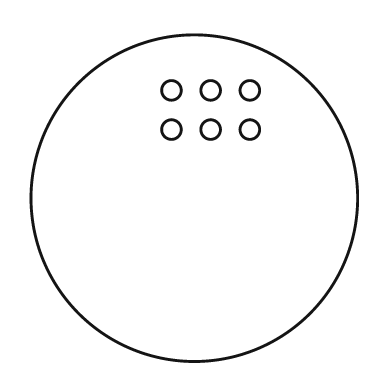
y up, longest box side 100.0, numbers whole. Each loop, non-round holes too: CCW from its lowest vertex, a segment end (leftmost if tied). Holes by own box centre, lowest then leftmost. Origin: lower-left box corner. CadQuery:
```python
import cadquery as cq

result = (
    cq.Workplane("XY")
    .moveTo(50.0, 50.0)
    .circle(50.0)
    .moveTo(43.0, 71.0)
    .circle(3.0)
    .moveTo(55.0, 71.0)
    .circle(3.0)
    .moveTo(67.0, 71.0)
    .circle(3.0)
    .moveTo(43.0, 83.0)
    .circle(3.0)
    .moveTo(55.0, 83.0)
    .circle(3.0)
    .moveTo(67.0, 83.0)
    .circle(3.0)
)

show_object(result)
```